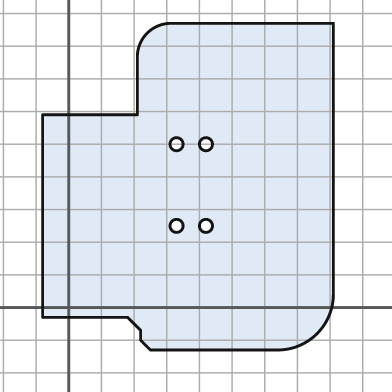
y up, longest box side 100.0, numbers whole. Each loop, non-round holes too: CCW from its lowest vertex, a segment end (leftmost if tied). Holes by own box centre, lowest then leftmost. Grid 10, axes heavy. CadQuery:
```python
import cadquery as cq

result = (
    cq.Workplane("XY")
    .moveTo(25.0, -13.0)
    .lineTo(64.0, -13.0)
    .threePointArc((76.0, -8.0), (81.0, 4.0))
    .lineTo(81.0, 87.0)
    .lineTo(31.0, 87.0)
    .threePointArc((24.0, 84.0), (21.0, 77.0))
    .lineTo(21.0, 59.0)
    .lineTo(-8.0, 59.0)
    .lineTo(-8.0, -3.0)
    .lineTo(18.0, -3.0)
    .lineTo(22.0, -7.0)
    .lineTo(22.0, -10.0)
    .close()
    .moveTo(33.0, 25.0)
    .circle(2.0)
    .moveTo(42.0, 25.0)
    .circle(2.0)
    .moveTo(33.0, 50.0)
    .circle(2.0)
    .moveTo(42.0, 50.0)
    .circle(2.0)
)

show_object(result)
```